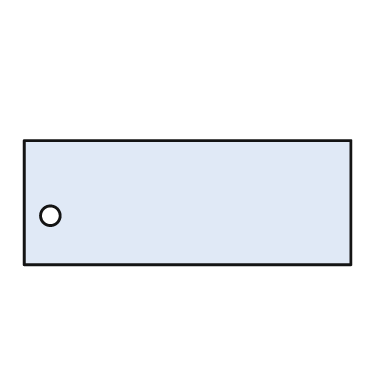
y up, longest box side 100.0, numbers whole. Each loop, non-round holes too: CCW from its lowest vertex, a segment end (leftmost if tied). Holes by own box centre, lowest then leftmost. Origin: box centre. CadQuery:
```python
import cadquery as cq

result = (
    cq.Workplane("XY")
    .moveTo(-50.0, -19.0)
    .lineTo(50.0, -19.0)
    .lineTo(50.0, 19.0)
    .lineTo(-50.0, 19.0)
    .close()
    .moveTo(-42.0, -4.0)
    .circle(3.0)
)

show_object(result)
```